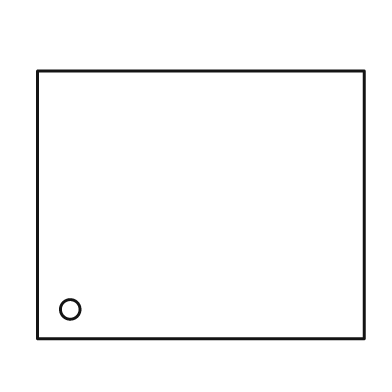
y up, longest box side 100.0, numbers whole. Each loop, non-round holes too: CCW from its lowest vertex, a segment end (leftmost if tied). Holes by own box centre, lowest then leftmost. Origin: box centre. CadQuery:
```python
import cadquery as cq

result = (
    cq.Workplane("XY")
    .moveTo(-50.0, -41.0)
    .lineTo(50.0, -41.0)
    .lineTo(50.0, 41.0)
    .lineTo(-50.0, 41.0)
    .close()
    .moveTo(-40.0, -32.0)
    .circle(3.0)
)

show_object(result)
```